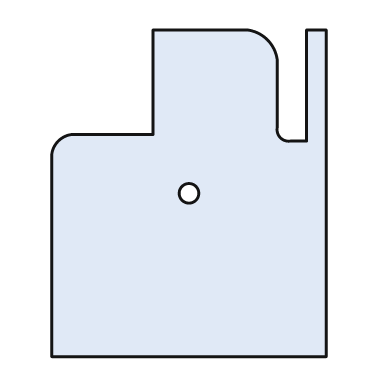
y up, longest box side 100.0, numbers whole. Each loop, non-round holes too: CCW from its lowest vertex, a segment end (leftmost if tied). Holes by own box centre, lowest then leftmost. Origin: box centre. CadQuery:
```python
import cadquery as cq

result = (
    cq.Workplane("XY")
    .moveTo(-42.0, -50.0)
    .lineTo(42.0, -50.0)
    .lineTo(42.0, 50.0)
    .lineTo(36.0, 50.0)
    .lineTo(36.0, 16.0)
    .lineTo(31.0, 16.0)
    .threePointArc((28.0, 17.0), (27.0, 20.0))
    .lineTo(27.0, 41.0)
    .threePointArc((24.0, 47.0), (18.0, 50.0))
    .lineTo(-11.0, 50.0)
    .lineTo(-11.0, 18.0)
    .lineTo(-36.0, 18.0)
    .threePointArc((-40.0, 16.0), (-42.0, 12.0))
    .close()
    .moveTo(0.0, 0.0)
    .circle(3.0)
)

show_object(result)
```